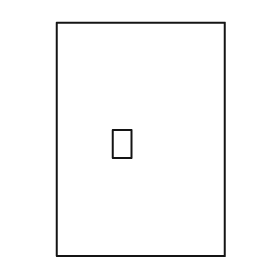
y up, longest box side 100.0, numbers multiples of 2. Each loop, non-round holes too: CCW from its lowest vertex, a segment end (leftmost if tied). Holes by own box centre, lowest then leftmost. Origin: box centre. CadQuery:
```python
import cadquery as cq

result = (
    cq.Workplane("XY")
    .moveTo(-36.0, -50.0)
    .lineTo(36.0, -50.0)
    .lineTo(36.0, 50.0)
    .lineTo(-36.0, 50.0)
    .close()
    .moveTo(-12.0, -8.0)
    .lineTo(-4.0, -8.0)
    .lineTo(-4.0, 4.0)
    .lineTo(-12.0, 4.0)
    .close()
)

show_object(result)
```